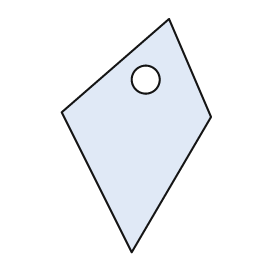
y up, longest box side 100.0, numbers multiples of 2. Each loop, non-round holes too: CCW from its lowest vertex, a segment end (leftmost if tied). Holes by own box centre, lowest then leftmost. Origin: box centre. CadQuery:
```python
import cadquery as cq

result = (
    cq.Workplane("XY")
    .moveTo(-2.0, -50.0)
    .lineTo(32.0, 8.0)
    .lineTo(14.0, 50.0)
    .lineTo(-32.0, 10.0)
    .close()
    .moveTo(4.0, 24.0)
    .circle(6.0)
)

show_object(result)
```